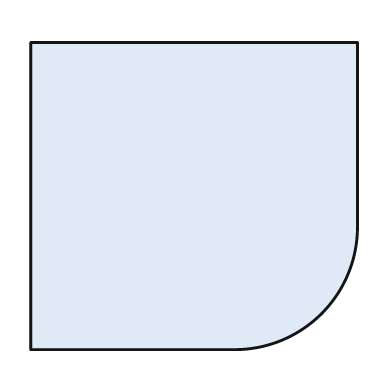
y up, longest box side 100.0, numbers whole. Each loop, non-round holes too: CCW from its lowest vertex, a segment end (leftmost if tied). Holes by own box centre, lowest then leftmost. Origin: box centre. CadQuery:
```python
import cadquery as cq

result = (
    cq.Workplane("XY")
    .moveTo(-50.0, -47.0)
    .lineTo(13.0, -47.0)
    .threePointArc((39.0, -36.0), (50.0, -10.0))
    .lineTo(50.0, 47.0)
    .lineTo(-50.0, 47.0)
    .close()
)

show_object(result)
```